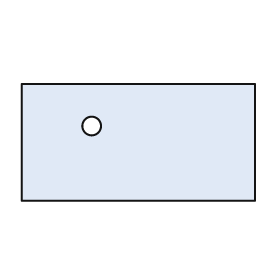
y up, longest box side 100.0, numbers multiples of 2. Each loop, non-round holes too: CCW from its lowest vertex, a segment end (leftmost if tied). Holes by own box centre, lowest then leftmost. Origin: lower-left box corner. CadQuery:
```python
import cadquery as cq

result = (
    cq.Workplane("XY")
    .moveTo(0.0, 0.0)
    .lineTo(100.0, 0.0)
    .lineTo(100.0, 50.0)
    .lineTo(0.0, 50.0)
    .close()
    .moveTo(30.0, 32.0)
    .circle(4.0)
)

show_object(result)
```